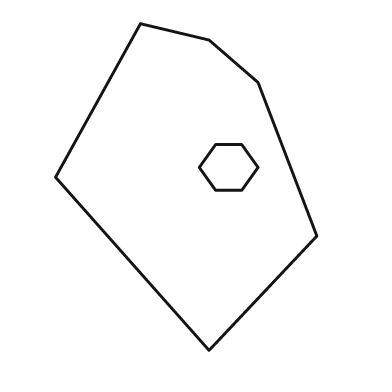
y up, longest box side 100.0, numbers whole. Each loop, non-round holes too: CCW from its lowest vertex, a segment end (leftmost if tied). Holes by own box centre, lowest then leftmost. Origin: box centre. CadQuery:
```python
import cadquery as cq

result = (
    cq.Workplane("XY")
    .moveTo(7.0, -50.0)
    .lineTo(40.0, -15.0)
    .lineTo(22.0, 32.0)
    .lineTo(7.0, 45.0)
    .lineTo(-14.0, 50.0)
    .lineTo(-40.0, 3.0)
    .close()
    .moveTo(9.0, -1.0)
    .lineTo(17.0, -1.0)
    .lineTo(22.0, 6.0)
    .lineTo(17.0, 13.0)
    .lineTo(9.0, 13.0)
    .lineTo(4.0, 6.0)
    .close()
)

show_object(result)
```